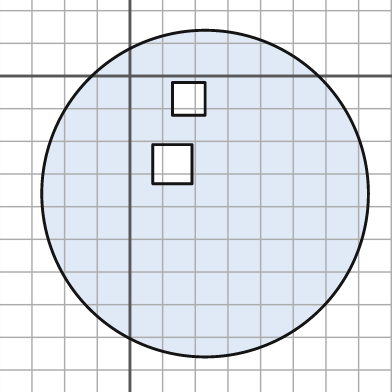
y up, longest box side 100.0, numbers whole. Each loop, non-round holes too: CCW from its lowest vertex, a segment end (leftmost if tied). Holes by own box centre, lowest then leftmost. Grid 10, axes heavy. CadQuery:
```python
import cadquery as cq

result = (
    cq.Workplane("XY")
    .moveTo(23.0, -36.0)
    .circle(50.0)
    .moveTo(7.0, -33.0)
    .lineTo(19.0, -33.0)
    .lineTo(19.0, -21.0)
    .lineTo(7.0, -21.0)
    .close()
    .moveTo(13.0, -12.0)
    .lineTo(23.0, -12.0)
    .lineTo(23.0, -2.0)
    .lineTo(13.0, -2.0)
    .close()
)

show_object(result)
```